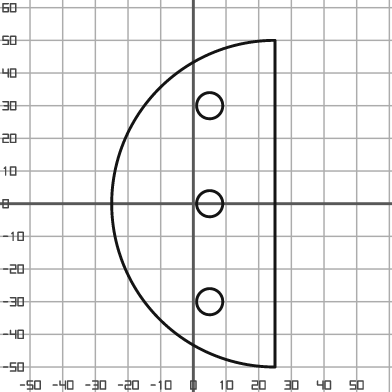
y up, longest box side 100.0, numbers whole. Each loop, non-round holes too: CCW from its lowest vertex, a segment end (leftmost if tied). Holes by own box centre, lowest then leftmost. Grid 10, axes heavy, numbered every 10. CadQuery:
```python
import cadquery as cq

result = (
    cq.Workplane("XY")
    .moveTo(25.0, -50.0)
    .lineTo(25.0, 50.0)
    .threePointArc((-25.0, 0.0), (25.0, -50.0))
    .close()
    .moveTo(5.0, -30.0)
    .circle(4.0)
    .moveTo(5.0, 0.0)
    .circle(4.0)
    .moveTo(5.0, 30.0)
    .circle(4.0)
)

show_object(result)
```